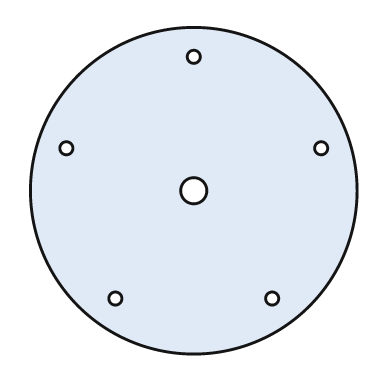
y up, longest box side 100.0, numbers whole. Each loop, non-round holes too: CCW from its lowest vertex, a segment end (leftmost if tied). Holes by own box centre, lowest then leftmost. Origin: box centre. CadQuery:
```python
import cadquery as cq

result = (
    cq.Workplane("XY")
    .moveTo(0.0, 0.0)
    .circle(50.0)
    .moveTo(-24.0, -33.0)
    .circle(2.0)
    .moveTo(24.0, -33.0)
    .circle(2.0)
    .moveTo(0.0, 0.0)
    .circle(4.0)
    .moveTo(-39.0, 13.0)
    .circle(2.0)
    .moveTo(39.0, 13.0)
    .circle(2.0)
    .moveTo(0.0, 41.0)
    .circle(2.0)
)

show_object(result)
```